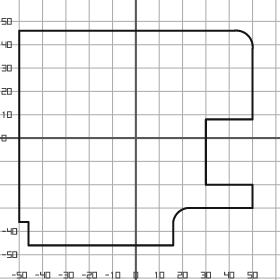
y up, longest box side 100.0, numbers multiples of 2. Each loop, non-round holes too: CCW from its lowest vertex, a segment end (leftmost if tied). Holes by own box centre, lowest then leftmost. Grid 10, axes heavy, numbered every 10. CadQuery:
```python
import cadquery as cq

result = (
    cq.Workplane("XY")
    .moveTo(-46.0, -46.0)
    .lineTo(16.0, -46.0)
    .lineTo(16.0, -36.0)
    .threePointArc((18.0, -32.0), (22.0, -30.0))
    .lineTo(50.0, -30.0)
    .lineTo(50.0, -20.0)
    .lineTo(30.0, -20.0)
    .lineTo(30.0, 8.0)
    .lineTo(50.0, 8.0)
    .lineTo(50.0, 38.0)
    .threePointArc((48.0, 44.0), (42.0, 46.0))
    .lineTo(-50.0, 46.0)
    .lineTo(-50.0, -36.0)
    .lineTo(-46.0, -36.0)
    .close()
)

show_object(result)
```